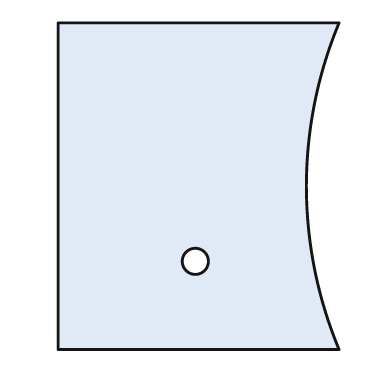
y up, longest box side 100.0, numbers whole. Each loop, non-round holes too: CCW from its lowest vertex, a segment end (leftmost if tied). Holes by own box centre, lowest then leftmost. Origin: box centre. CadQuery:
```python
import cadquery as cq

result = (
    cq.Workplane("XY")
    .moveTo(-43.0, -50.0)
    .lineTo(43.0, -50.0)
    .threePointArc((33.0, 0.0), (43.0, 50.0))
    .lineTo(-43.0, 50.0)
    .close()
    .moveTo(-1.0, -23.0)
    .circle(4.0)
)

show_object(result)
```